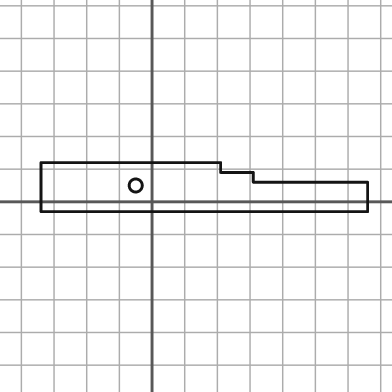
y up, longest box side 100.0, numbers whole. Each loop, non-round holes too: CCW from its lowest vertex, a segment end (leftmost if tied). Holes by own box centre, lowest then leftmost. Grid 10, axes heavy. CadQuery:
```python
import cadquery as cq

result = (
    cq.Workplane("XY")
    .moveTo(-34.0, -3.0)
    .lineTo(66.0, -3.0)
    .lineTo(66.0, 6.0)
    .lineTo(31.0, 6.0)
    .lineTo(31.0, 9.0)
    .lineTo(21.0, 9.0)
    .lineTo(21.0, 12.0)
    .lineTo(-34.0, 12.0)
    .close()
    .moveTo(-5.0, 5.0)
    .circle(2.0)
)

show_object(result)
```